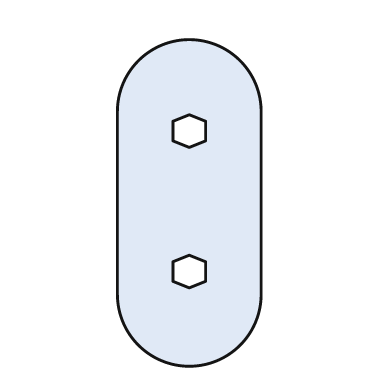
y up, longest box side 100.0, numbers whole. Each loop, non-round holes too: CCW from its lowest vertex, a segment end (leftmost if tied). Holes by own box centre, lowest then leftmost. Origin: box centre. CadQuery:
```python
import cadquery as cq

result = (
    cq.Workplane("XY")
    .moveTo(-22.0, -28.0)
    .threePointArc((0.0, -50.0), (22.0, -28.0))
    .lineTo(22.0, 28.0)
    .threePointArc((0.0, 50.0), (-22.0, 28.0))
    .close()
    .moveTo(0.0, -26.0)
    .lineTo(5.0, -24.0)
    .lineTo(5.0, -18.0)
    .lineTo(0.0, -16.0)
    .lineTo(-5.0, -18.0)
    .lineTo(-5.0, -24.0)
    .close()
    .moveTo(0.0, 17.0)
    .lineTo(5.0, 19.0)
    .lineTo(5.0, 25.0)
    .lineTo(0.0, 27.0)
    .lineTo(-5.0, 25.0)
    .lineTo(-5.0, 19.0)
    .close()
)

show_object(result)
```